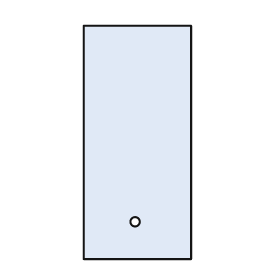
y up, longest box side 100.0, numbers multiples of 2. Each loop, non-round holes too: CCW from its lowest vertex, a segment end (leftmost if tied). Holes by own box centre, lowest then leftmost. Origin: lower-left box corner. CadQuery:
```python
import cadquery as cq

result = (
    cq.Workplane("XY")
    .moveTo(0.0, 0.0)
    .lineTo(46.0, 0.0)
    .lineTo(46.0, 100.0)
    .lineTo(0.0, 100.0)
    .close()
    .moveTo(22.0, 16.0)
    .circle(2.0)
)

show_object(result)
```